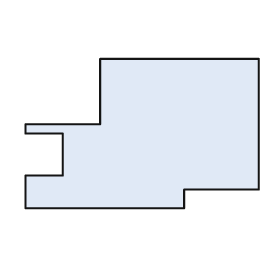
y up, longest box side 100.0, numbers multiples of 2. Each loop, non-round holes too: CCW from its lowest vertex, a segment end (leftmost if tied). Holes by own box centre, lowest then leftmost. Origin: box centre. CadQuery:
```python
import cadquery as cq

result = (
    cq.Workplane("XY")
    .moveTo(-50.0, -32.0)
    .lineTo(18.0, -32.0)
    .lineTo(18.0, -24.0)
    .lineTo(50.0, -24.0)
    .lineTo(50.0, 32.0)
    .lineTo(-18.0, 32.0)
    .lineTo(-18.0, 4.0)
    .lineTo(-50.0, 4.0)
    .lineTo(-50.0, 0.0)
    .lineTo(-34.0, 0.0)
    .lineTo(-34.0, -18.0)
    .lineTo(-50.0, -18.0)
    .close()
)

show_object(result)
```